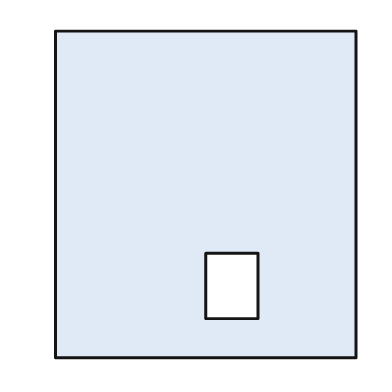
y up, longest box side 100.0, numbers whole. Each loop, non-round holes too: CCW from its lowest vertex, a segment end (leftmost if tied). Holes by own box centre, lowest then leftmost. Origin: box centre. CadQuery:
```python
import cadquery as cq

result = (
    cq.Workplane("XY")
    .moveTo(-46.0, -50.0)
    .lineTo(46.0, -50.0)
    .lineTo(46.0, 50.0)
    .lineTo(-46.0, 50.0)
    .close()
    .moveTo(0.0, -38.0)
    .lineTo(16.0, -38.0)
    .lineTo(16.0, -18.0)
    .lineTo(0.0, -18.0)
    .close()
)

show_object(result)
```